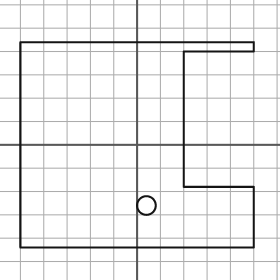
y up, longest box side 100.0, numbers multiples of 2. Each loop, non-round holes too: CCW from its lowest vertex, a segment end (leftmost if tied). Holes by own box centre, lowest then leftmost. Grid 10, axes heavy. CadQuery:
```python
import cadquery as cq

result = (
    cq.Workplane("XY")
    .moveTo(-50.0, -44.0)
    .lineTo(50.0, -44.0)
    .lineTo(50.0, -18.0)
    .lineTo(20.0, -18.0)
    .lineTo(20.0, 40.0)
    .lineTo(50.0, 40.0)
    .lineTo(50.0, 44.0)
    .lineTo(-50.0, 44.0)
    .close()
    .moveTo(4.0, -26.0)
    .circle(4.0)
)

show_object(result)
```